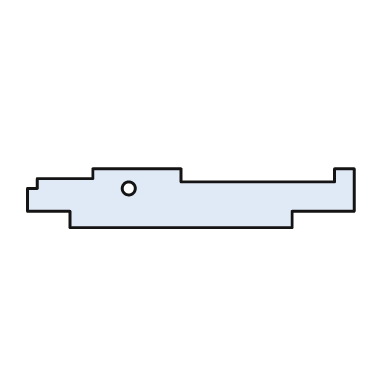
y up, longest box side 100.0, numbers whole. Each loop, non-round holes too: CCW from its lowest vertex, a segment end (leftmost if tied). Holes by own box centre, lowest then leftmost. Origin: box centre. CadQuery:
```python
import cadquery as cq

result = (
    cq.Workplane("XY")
    .moveTo(-37.0, -9.0)
    .lineTo(31.0, -9.0)
    .lineTo(31.0, -4.0)
    .lineTo(50.0, -4.0)
    .lineTo(50.0, 9.0)
    .lineTo(44.0, 9.0)
    .lineTo(44.0, 5.0)
    .lineTo(-3.0, 5.0)
    .lineTo(-3.0, 9.0)
    .lineTo(-30.0, 9.0)
    .lineTo(-30.0, 6.0)
    .lineTo(-47.0, 6.0)
    .lineTo(-47.0, 3.0)
    .lineTo(-50.0, 3.0)
    .lineTo(-50.0, -4.0)
    .lineTo(-37.0, -4.0)
    .close()
    .moveTo(-19.0, 3.0)
    .circle(2.0)
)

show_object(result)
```